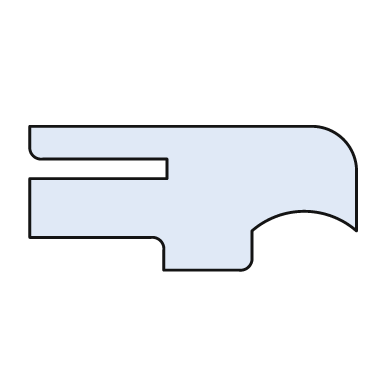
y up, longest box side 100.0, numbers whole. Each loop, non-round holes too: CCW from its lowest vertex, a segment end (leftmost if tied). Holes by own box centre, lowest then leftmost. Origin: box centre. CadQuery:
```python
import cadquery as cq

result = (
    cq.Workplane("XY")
    .moveTo(-9.0, -22.0)
    .lineTo(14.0, -22.0)
    .threePointArc((17.0, -21.0), (18.0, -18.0))
    .lineTo(18.0, -10.0)
    .threePointArc((34.0, -4.0), (50.0, -10.0))
    .lineTo(50.0, 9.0)
    .threePointArc((46.0, 18.0), (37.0, 22.0))
    .lineTo(-50.0, 22.0)
    .lineTo(-50.0, 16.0)
    .threePointArc((-49.0, 13.0), (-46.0, 12.0))
    .lineTo(-8.0, 12.0)
    .lineTo(-8.0, 6.0)
    .lineTo(-50.0, 6.0)
    .lineTo(-50.0, -12.0)
    .lineTo(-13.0, -12.0)
    .threePointArc((-10.0, -13.0), (-9.0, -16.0))
    .close()
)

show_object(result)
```